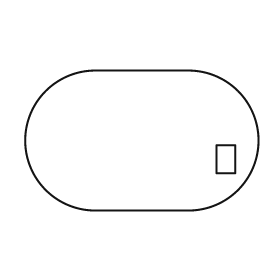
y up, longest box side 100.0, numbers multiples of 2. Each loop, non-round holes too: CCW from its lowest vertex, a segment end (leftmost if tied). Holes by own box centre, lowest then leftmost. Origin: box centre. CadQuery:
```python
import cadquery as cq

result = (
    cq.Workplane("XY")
    .moveTo(-20.0, -30.0)
    .lineTo(20.0, -30.0)
    .threePointArc((50.0, 0.0), (20.0, 30.0))
    .lineTo(-20.0, 30.0)
    .threePointArc((-50.0, 0.0), (-20.0, -30.0))
    .close()
    .moveTo(32.0, -14.0)
    .lineTo(40.0, -14.0)
    .lineTo(40.0, -2.0)
    .lineTo(32.0, -2.0)
    .close()
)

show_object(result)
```